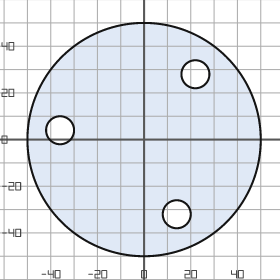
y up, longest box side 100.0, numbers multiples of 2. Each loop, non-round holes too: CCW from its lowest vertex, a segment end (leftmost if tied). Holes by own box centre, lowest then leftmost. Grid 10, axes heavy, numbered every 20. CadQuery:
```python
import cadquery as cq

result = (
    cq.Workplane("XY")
    .moveTo(0.0, 0.0)
    .circle(50.0)
    .moveTo(14.0, -32.0)
    .circle(6.0)
    .moveTo(-36.0, 4.0)
    .circle(6.0)
    .moveTo(22.0, 28.0)
    .circle(6.0)
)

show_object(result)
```